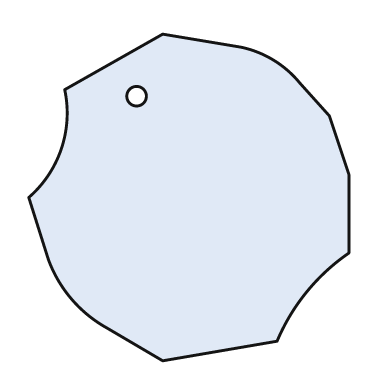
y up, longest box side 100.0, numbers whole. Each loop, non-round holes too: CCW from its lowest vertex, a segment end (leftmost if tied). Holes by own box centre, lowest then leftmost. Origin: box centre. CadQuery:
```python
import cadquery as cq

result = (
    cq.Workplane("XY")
    .moveTo(-8.0, -50.0)
    .lineTo(27.0, -44.0)
    .threePointArc((36.0, -29.0), (49.0, -17.0))
    .lineTo(49.0, 7.0)
    .lineTo(43.0, 25.0)
    .lineTo(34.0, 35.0)
    .threePointArc((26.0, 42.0), (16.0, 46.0))
    .lineTo(-8.0, 50.0)
    .lineTo(-38.0, 33.0)
    .threePointArc((-39.0, 15.0), (-49.0, 0.0))
    .lineTo(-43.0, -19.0)
    .threePointArc((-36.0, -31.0), (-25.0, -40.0))
    .close()
    .moveTo(-16.0, 31.0)
    .circle(3.0)
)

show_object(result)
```